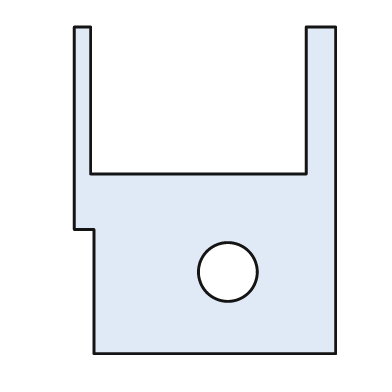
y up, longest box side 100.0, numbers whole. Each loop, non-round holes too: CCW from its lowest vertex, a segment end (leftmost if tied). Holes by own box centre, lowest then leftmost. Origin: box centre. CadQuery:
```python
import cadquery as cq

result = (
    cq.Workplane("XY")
    .moveTo(-34.0, -50.0)
    .lineTo(40.0, -50.0)
    .lineTo(40.0, 50.0)
    .lineTo(31.0, 50.0)
    .lineTo(31.0, 5.0)
    .lineTo(-35.0, 5.0)
    .lineTo(-35.0, 50.0)
    .lineTo(-40.0, 50.0)
    .lineTo(-40.0, -12.0)
    .lineTo(-34.0, -12.0)
    .close()
    .moveTo(7.0, -25.0)
    .circle(9.0)
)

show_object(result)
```